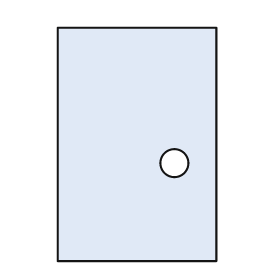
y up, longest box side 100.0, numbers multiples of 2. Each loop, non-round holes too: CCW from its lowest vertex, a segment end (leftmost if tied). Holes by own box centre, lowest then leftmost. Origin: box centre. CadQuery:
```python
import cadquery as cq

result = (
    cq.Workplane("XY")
    .moveTo(-34.0, -50.0)
    .lineTo(34.0, -50.0)
    .lineTo(34.0, 50.0)
    .lineTo(-34.0, 50.0)
    .close()
    .moveTo(16.0, -8.0)
    .circle(6.0)
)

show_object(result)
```